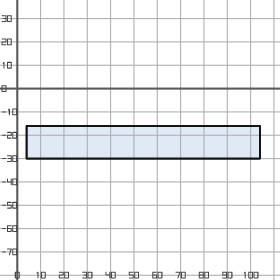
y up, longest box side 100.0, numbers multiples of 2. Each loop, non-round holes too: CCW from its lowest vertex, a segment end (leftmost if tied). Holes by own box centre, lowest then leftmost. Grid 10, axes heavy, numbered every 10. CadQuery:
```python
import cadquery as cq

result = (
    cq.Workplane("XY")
    .moveTo(4.0, -30.0)
    .lineTo(104.0, -30.0)
    .lineTo(104.0, -16.0)
    .lineTo(4.0, -16.0)
    .close()
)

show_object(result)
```